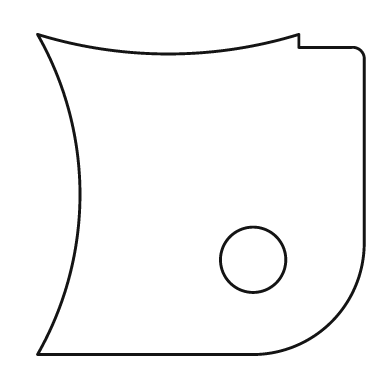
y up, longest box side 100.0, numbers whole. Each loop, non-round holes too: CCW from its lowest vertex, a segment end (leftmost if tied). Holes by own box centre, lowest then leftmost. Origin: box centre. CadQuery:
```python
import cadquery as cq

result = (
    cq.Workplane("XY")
    .moveTo(-50.0, -49.0)
    .lineTo(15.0, -49.0)
    .threePointArc((40.0, -39.0), (50.0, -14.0))
    .lineTo(50.0, 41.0)
    .threePointArc((49.0, 44.0), (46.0, 45.0))
    .lineTo(30.0, 45.0)
    .lineTo(30.0, 49.0)
    .threePointArc((-10.0, 43.0), (-50.0, 49.0))
    .threePointArc((-37.0, 0.0), (-50.0, -49.0))
    .close()
    .moveTo(16.0, -20.0)
    .circle(10.0)
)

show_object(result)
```